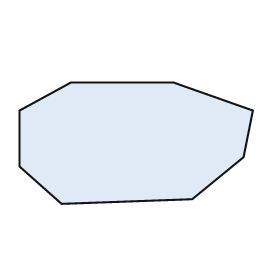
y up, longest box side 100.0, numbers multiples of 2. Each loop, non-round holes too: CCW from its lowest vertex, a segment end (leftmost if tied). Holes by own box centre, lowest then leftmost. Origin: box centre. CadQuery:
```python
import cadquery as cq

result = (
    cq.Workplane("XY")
    .moveTo(-32.0, -26.0)
    .lineTo(24.0, -24.0)
    .lineTo(46.0, -6.0)
    .lineTo(50.0, 14.0)
    .lineTo(16.0, 26.0)
    .lineTo(-28.0, 26.0)
    .lineTo(-50.0, 14.0)
    .lineTo(-50.0, -10.0)
    .close()
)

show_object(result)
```